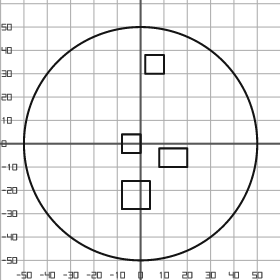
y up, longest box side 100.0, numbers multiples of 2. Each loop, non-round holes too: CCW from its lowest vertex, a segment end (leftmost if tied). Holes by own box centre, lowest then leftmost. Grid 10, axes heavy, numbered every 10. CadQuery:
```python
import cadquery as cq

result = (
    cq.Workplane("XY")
    .moveTo(0.0, 0.0)
    .circle(50.0)
    .moveTo(-8.0, -28.0)
    .lineTo(4.0, -28.0)
    .lineTo(4.0, -16.0)
    .lineTo(-8.0, -16.0)
    .close()
    .moveTo(8.0, -10.0)
    .lineTo(20.0, -10.0)
    .lineTo(20.0, -2.0)
    .lineTo(8.0, -2.0)
    .close()
    .moveTo(-8.0, -4.0)
    .lineTo(0.0, -4.0)
    .lineTo(0.0, 4.0)
    .lineTo(-8.0, 4.0)
    .close()
    .moveTo(2.0, 30.0)
    .lineTo(10.0, 30.0)
    .lineTo(10.0, 38.0)
    .lineTo(2.0, 38.0)
    .close()
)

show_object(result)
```